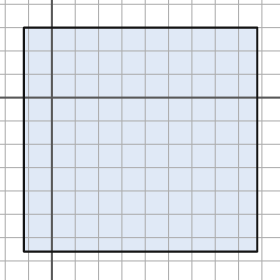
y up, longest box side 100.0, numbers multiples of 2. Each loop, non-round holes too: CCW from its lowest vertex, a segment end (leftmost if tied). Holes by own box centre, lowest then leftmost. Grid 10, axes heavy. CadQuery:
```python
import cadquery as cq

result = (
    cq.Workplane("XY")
    .moveTo(-12.0, -66.0)
    .lineTo(88.0, -66.0)
    .lineTo(88.0, 30.0)
    .lineTo(-12.0, 30.0)
    .close()
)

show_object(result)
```